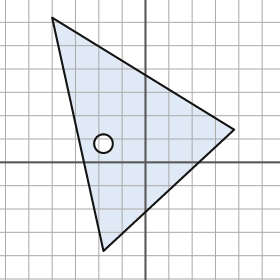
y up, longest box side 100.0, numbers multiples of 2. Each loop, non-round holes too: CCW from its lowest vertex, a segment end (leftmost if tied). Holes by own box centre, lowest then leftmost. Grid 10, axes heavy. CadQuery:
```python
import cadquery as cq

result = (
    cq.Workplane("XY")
    .moveTo(-18.0, -38.0)
    .lineTo(38.0, 14.0)
    .lineTo(-40.0, 62.0)
    .close()
    .moveTo(-18.0, 8.0)
    .circle(4.0)
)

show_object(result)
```